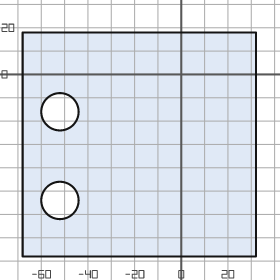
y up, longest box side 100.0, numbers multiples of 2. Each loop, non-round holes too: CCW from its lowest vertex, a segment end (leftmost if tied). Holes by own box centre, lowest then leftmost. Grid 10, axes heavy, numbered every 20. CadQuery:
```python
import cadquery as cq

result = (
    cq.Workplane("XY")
    .moveTo(-68.0, -78.0)
    .lineTo(32.0, -78.0)
    .lineTo(32.0, 18.0)
    .lineTo(-68.0, 18.0)
    .close()
    .moveTo(-52.0, -54.0)
    .circle(8.0)
    .moveTo(-52.0, -16.0)
    .circle(8.0)
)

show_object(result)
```